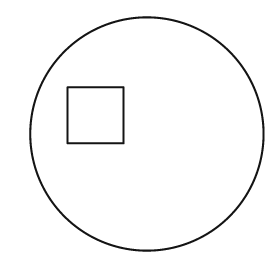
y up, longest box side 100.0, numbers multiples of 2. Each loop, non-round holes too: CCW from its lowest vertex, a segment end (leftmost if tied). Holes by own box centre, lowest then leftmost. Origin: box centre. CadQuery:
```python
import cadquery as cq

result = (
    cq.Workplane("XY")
    .moveTo(0.0, 0.0)
    .circle(50.0)
    .moveTo(-34.0, -4.0)
    .lineTo(-10.0, -4.0)
    .lineTo(-10.0, 20.0)
    .lineTo(-34.0, 20.0)
    .close()
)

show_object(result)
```